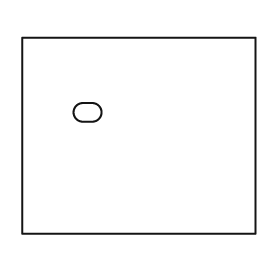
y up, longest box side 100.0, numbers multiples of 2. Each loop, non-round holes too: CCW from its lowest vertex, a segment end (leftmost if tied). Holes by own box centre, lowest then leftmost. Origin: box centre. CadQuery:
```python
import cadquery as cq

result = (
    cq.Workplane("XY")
    .moveTo(-50.0, -42.0)
    .lineTo(50.0, -42.0)
    .lineTo(50.0, 42.0)
    .lineTo(-50.0, 42.0)
    .close()
    .moveTo(-24.0, 6.0)
    .lineTo(-20.0, 6.0)
    .threePointArc((-16.0, 10.0), (-20.0, 14.0))
    .lineTo(-24.0, 14.0)
    .threePointArc((-28.0, 10.0), (-24.0, 6.0))
    .close()
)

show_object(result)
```